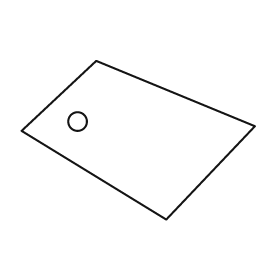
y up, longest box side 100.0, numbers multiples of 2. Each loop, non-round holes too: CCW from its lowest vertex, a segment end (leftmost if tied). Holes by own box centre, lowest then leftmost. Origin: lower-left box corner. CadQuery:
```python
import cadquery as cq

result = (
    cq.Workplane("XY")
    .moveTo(62.0, 0.0)
    .lineTo(100.0, 40.0)
    .lineTo(32.0, 68.0)
    .lineTo(0.0, 38.0)
    .close()
    .moveTo(24.0, 42.0)
    .circle(4.0)
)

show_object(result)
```